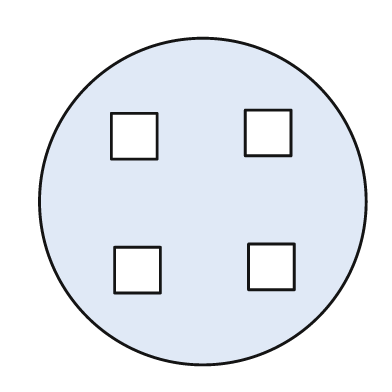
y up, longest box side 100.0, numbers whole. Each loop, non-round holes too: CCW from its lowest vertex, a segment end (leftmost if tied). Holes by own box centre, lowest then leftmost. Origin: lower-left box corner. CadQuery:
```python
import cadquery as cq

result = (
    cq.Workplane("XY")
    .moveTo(50.0, 50.0)
    .circle(50.0)
    .moveTo(23.0, 22.0)
    .lineTo(37.0, 22.0)
    .lineTo(37.0, 36.0)
    .lineTo(23.0, 36.0)
    .close()
    .moveTo(64.0, 23.0)
    .lineTo(78.0, 23.0)
    .lineTo(78.0, 37.0)
    .lineTo(64.0, 37.0)
    .close()
    .moveTo(22.0, 63.0)
    .lineTo(36.0, 63.0)
    .lineTo(36.0, 77.0)
    .lineTo(22.0, 77.0)
    .close()
    .moveTo(63.0, 64.0)
    .lineTo(77.0, 64.0)
    .lineTo(77.0, 78.0)
    .lineTo(63.0, 78.0)
    .close()
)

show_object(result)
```